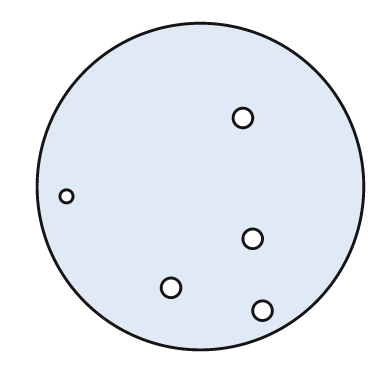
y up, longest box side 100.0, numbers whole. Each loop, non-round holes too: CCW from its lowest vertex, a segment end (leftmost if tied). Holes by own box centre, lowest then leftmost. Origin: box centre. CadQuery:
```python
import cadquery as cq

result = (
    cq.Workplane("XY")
    .moveTo(0.0, 0.0)
    .circle(50.0)
    .moveTo(19.0, -38.0)
    .circle(3.0)
    .moveTo(-9.0, -31.0)
    .circle(3.0)
    .moveTo(16.0, -16.0)
    .circle(3.0)
    .moveTo(-41.0, -3.0)
    .circle(2.0)
    .moveTo(13.0, 21.0)
    .circle(3.0)
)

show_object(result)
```